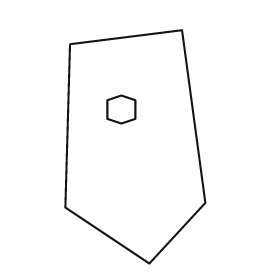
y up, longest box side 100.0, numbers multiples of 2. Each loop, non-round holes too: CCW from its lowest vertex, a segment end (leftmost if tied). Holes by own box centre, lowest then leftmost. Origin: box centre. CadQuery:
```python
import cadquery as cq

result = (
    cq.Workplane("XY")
    .moveTo(6.0, -50.0)
    .lineTo(30.0, -24.0)
    .lineTo(20.0, 50.0)
    .lineTo(-28.0, 44.0)
    .lineTo(-30.0, -26.0)
    .close()
    .moveTo(-6.0, 10.0)
    .lineTo(0.0, 12.0)
    .lineTo(0.0, 20.0)
    .lineTo(-6.0, 22.0)
    .lineTo(-12.0, 20.0)
    .lineTo(-12.0, 12.0)
    .close()
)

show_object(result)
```